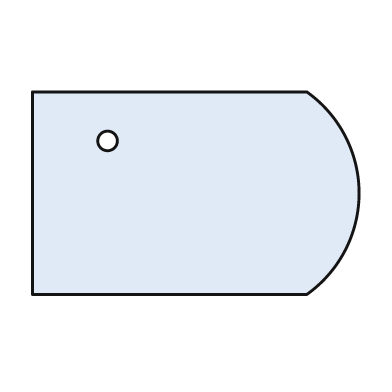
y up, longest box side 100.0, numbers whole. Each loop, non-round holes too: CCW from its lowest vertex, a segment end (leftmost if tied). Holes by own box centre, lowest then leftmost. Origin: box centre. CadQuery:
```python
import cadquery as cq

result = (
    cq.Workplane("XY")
    .moveTo(-50.0, -31.0)
    .lineTo(34.0, -31.0)
    .threePointArc((50.0, 0.0), (34.0, 31.0))
    .lineTo(-50.0, 31.0)
    .close()
    .moveTo(-27.0, 16.0)
    .circle(3.0)
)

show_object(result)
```